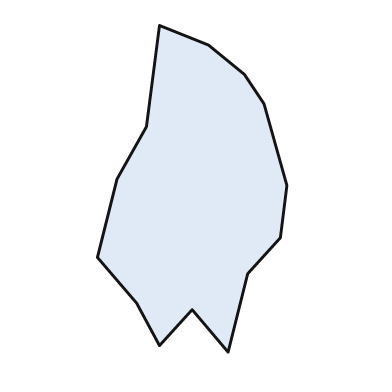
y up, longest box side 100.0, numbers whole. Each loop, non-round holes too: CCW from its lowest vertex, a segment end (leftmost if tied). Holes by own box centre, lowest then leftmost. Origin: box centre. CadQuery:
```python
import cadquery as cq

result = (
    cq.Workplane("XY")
    .moveTo(11.0, -50.0)
    .lineTo(17.0, -26.0)
    .lineTo(27.0, -15.0)
    .lineTo(29.0, 1.0)
    .lineTo(22.0, 26.0)
    .lineTo(16.0, 35.0)
    .lineTo(5.0, 44.0)
    .lineTo(-10.0, 50.0)
    .lineTo(-14.0, 19.0)
    .lineTo(-23.0, 3.0)
    .lineTo(-29.0, -21.0)
    .lineTo(-17.0, -35.0)
    .lineTo(-10.0, -48.0)
    .lineTo(0.0, -37.0)
    .close()
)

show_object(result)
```